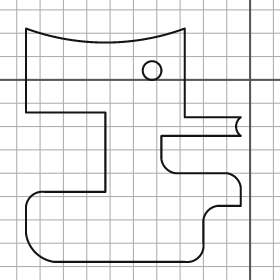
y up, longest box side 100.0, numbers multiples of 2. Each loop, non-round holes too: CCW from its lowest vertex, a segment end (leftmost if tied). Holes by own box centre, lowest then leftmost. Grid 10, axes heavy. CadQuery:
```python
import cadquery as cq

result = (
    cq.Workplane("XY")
    .moveTo(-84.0, -78.0)
    .lineTo(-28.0, -78.0)
    .threePointArc((-22.0, -76.0), (-20.0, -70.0))
    .lineTo(-20.0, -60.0)
    .threePointArc((-18.0, -56.0), (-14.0, -54.0))
    .lineTo(-4.0, -54.0)
    .lineTo(-4.0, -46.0)
    .threePointArc((-6.0, -42.0), (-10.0, -40.0))
    .lineTo(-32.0, -40.0)
    .threePointArc((-36.0, -38.0), (-38.0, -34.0))
    .lineTo(-38.0, -24.0)
    .lineTo(-4.0, -24.0)
    .threePointArc((-6.0, -20.0), (-4.0, -16.0))
    .lineTo(-28.0, -16.0)
    .lineTo(-28.0, 22.0)
    .threePointArc((-62.0, 16.0), (-96.0, 22.0))
    .lineTo(-96.0, -14.0)
    .lineTo(-62.0, -14.0)
    .lineTo(-62.0, -48.0)
    .lineTo(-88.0, -48.0)
    .threePointArc((-94.0, -50.0), (-96.0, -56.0))
    .lineTo(-96.0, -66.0)
    .threePointArc((-92.0, -74.0), (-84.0, -78.0))
    .close()
    .moveTo(-42.0, 4.0)
    .circle(4.0)
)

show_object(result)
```